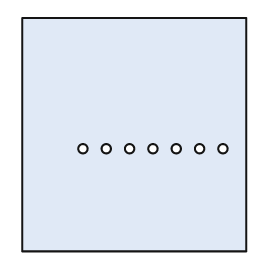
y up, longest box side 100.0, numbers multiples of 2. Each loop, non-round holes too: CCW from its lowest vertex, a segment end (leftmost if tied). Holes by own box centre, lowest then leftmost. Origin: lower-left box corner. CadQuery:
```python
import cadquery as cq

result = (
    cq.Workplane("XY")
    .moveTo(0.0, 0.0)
    .lineTo(96.0, 0.0)
    .lineTo(96.0, 100.0)
    .lineTo(0.0, 100.0)
    .close()
    .moveTo(26.0, 44.0)
    .circle(2.0)
    .moveTo(36.0, 44.0)
    .circle(2.0)
    .moveTo(46.0, 44.0)
    .circle(2.0)
    .moveTo(56.0, 44.0)
    .circle(2.0)
    .moveTo(66.0, 44.0)
    .circle(2.0)
    .moveTo(76.0, 44.0)
    .circle(2.0)
    .moveTo(86.0, 44.0)
    .circle(2.0)
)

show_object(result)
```